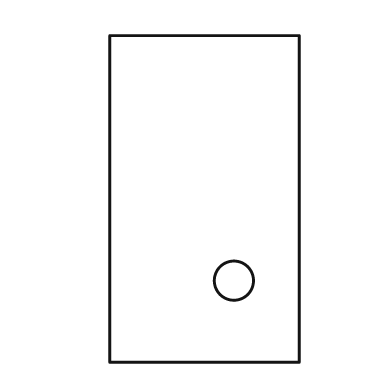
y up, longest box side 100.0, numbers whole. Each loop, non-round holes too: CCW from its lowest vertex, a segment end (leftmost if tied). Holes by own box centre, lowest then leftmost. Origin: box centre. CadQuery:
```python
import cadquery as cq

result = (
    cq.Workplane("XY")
    .moveTo(-29.0, -50.0)
    .lineTo(29.0, -50.0)
    .lineTo(29.0, 50.0)
    .lineTo(-29.0, 50.0)
    .close()
    .moveTo(9.0, -25.0)
    .circle(6.0)
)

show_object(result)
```